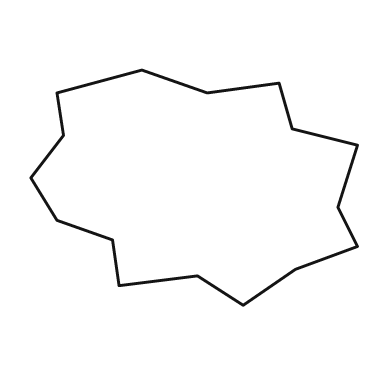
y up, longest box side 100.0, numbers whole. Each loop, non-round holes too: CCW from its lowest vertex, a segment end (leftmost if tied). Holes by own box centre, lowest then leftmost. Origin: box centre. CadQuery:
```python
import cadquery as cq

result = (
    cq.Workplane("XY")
    .moveTo(15.0, -36.0)
    .lineTo(31.0, -25.0)
    .lineTo(50.0, -18.0)
    .lineTo(44.0, -6.0)
    .lineTo(50.0, 13.0)
    .lineTo(30.0, 18.0)
    .lineTo(26.0, 32.0)
    .lineTo(4.0, 29.0)
    .lineTo(-16.0, 36.0)
    .lineTo(-42.0, 29.0)
    .lineTo(-40.0, 16.0)
    .lineTo(-50.0, 3.0)
    .lineTo(-42.0, -10.0)
    .lineTo(-25.0, -16.0)
    .lineTo(-23.0, -30.0)
    .lineTo(1.0, -27.0)
    .close()
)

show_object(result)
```